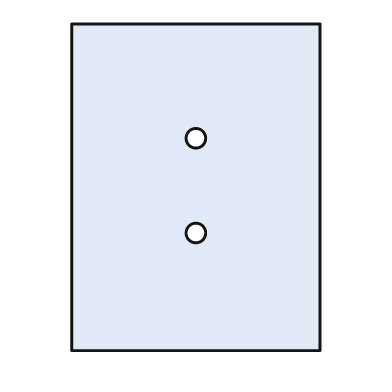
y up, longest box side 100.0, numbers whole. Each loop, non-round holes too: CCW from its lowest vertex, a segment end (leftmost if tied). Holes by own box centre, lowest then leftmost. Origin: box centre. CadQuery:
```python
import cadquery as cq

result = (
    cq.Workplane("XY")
    .moveTo(-38.0, -50.0)
    .lineTo(38.0, -50.0)
    .lineTo(38.0, 50.0)
    .lineTo(-38.0, 50.0)
    .close()
    .moveTo(0.0, -14.0)
    .circle(3.0)
    .moveTo(0.0, 15.0)
    .circle(3.0)
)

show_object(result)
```